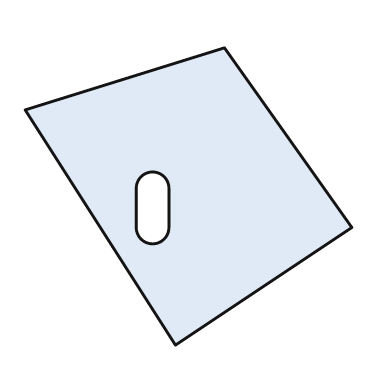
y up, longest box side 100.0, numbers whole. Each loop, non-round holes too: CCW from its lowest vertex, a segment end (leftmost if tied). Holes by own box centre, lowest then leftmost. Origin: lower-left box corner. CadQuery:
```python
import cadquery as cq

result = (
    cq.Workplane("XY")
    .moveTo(46.0, 0.0)
    .lineTo(100.0, 36.0)
    .lineTo(61.0, 91.0)
    .lineTo(0.0, 72.0)
    .close()
    .moveTo(34.0, 36.0)
    .threePointArc((39.0, 31.0), (44.0, 36.0))
    .lineTo(44.0, 48.0)
    .threePointArc((39.0, 53.0), (34.0, 48.0))
    .close()
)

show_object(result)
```